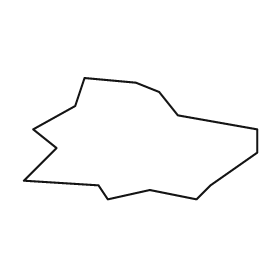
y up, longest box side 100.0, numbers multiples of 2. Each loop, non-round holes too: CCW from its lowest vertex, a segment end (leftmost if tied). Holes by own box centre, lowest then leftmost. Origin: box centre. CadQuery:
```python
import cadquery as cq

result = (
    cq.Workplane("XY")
    .moveTo(-14.0, -26.0)
    .lineTo(4.0, -22.0)
    .lineTo(24.0, -26.0)
    .lineTo(30.0, -20.0)
    .lineTo(50.0, -6.0)
    .lineTo(50.0, 4.0)
    .lineTo(16.0, 10.0)
    .lineTo(8.0, 20.0)
    .lineTo(-2.0, 24.0)
    .lineTo(-24.0, 26.0)
    .lineTo(-28.0, 14.0)
    .lineTo(-46.0, 4.0)
    .lineTo(-36.0, -4.0)
    .lineTo(-50.0, -18.0)
    .lineTo(-18.0, -20.0)
    .close()
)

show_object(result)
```